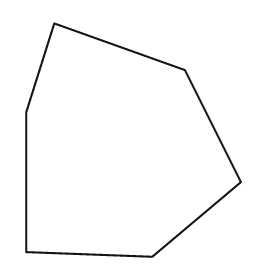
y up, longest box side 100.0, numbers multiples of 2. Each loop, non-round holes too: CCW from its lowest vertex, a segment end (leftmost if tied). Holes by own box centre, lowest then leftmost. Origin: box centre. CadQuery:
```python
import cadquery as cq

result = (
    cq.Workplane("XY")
    .moveTo(8.0, -50.0)
    .lineTo(46.0, -18.0)
    .lineTo(22.0, 30.0)
    .lineTo(-34.0, 50.0)
    .lineTo(-46.0, 12.0)
    .lineTo(-46.0, -48.0)
    .close()
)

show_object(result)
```